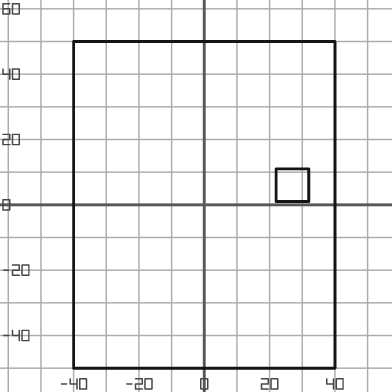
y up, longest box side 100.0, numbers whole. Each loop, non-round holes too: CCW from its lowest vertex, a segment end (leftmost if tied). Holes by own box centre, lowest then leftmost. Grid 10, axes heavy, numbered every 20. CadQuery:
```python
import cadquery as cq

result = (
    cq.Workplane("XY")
    .moveTo(-40.0, -50.0)
    .lineTo(40.0, -50.0)
    .lineTo(40.0, 50.0)
    .lineTo(-40.0, 50.0)
    .close()
    .moveTo(22.0, 1.0)
    .lineTo(32.0, 1.0)
    .lineTo(32.0, 11.0)
    .lineTo(22.0, 11.0)
    .close()
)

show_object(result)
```